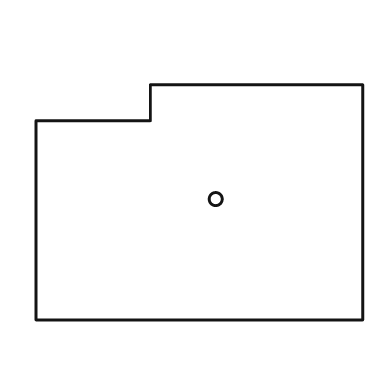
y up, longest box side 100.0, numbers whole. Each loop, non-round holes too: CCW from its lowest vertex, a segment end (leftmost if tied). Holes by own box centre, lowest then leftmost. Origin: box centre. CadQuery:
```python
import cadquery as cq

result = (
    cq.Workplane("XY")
    .moveTo(-50.0, -36.0)
    .lineTo(50.0, -36.0)
    .lineTo(50.0, 36.0)
    .lineTo(-15.0, 36.0)
    .lineTo(-15.0, 25.0)
    .lineTo(-50.0, 25.0)
    .close()
    .moveTo(5.0, 1.0)
    .circle(2.0)
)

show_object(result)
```